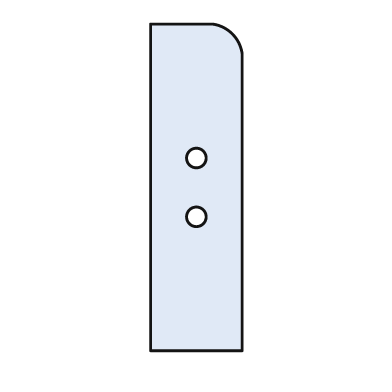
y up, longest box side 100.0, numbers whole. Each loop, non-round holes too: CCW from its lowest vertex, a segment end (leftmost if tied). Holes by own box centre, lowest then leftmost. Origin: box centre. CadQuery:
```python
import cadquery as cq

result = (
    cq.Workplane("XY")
    .moveTo(-14.0, -50.0)
    .lineTo(14.0, -50.0)
    .lineTo(14.0, 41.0)
    .threePointArc((11.0, 47.0), (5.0, 50.0))
    .lineTo(-14.0, 50.0)
    .close()
    .moveTo(0.0, -9.0)
    .circle(3.0)
    .moveTo(0.0, 9.0)
    .circle(3.0)
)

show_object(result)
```